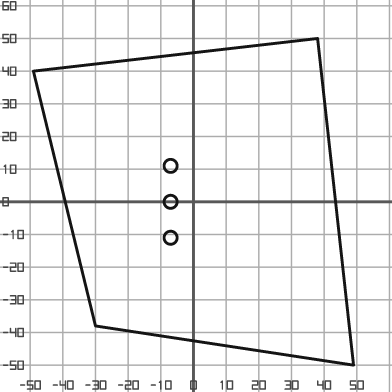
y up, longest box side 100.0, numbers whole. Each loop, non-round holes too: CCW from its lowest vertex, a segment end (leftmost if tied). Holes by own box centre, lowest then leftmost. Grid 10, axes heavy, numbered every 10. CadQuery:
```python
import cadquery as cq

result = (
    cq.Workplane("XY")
    .moveTo(49.0, -50.0)
    .lineTo(38.0, 50.0)
    .lineTo(-49.0, 40.0)
    .lineTo(-30.0, -38.0)
    .close()
    .moveTo(-7.0, -11.0)
    .circle(2.0)
    .moveTo(-7.0, 0.0)
    .circle(2.0)
    .moveTo(-7.0, 11.0)
    .circle(2.0)
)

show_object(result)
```